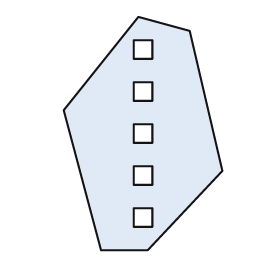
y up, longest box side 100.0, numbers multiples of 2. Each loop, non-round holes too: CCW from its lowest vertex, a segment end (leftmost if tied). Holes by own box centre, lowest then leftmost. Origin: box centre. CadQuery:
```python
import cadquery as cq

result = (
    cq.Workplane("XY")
    .moveTo(-18.0, -50.0)
    .lineTo(2.0, -50.0)
    .lineTo(34.0, -16.0)
    .lineTo(20.0, 44.0)
    .lineTo(-2.0, 50.0)
    .lineTo(-34.0, 10.0)
    .close()
    .moveTo(-4.0, -40.0)
    .lineTo(4.0, -40.0)
    .lineTo(4.0, -32.0)
    .lineTo(-4.0, -32.0)
    .close()
    .moveTo(-4.0, -22.0)
    .lineTo(4.0, -22.0)
    .lineTo(4.0, -14.0)
    .lineTo(-4.0, -14.0)
    .close()
    .moveTo(-4.0, -4.0)
    .lineTo(4.0, -4.0)
    .lineTo(4.0, 4.0)
    .lineTo(-4.0, 4.0)
    .close()
    .moveTo(-4.0, 14.0)
    .lineTo(4.0, 14.0)
    .lineTo(4.0, 22.0)
    .lineTo(-4.0, 22.0)
    .close()
    .moveTo(-4.0, 32.0)
    .lineTo(4.0, 32.0)
    .lineTo(4.0, 40.0)
    .lineTo(-4.0, 40.0)
    .close()
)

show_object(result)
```